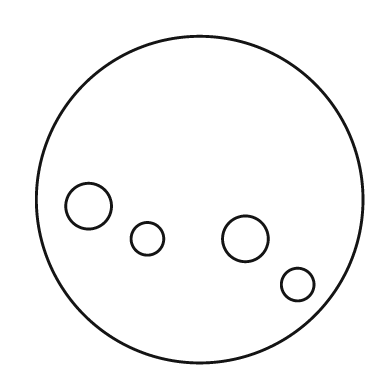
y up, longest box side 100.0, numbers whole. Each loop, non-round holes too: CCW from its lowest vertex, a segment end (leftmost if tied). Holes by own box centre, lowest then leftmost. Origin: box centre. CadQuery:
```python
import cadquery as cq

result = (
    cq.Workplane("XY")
    .moveTo(0.0, 0.0)
    .circle(50.0)
    .moveTo(30.0, -26.0)
    .circle(5.0)
    .moveTo(-16.0, -12.0)
    .circle(5.0)
    .moveTo(14.0, -12.0)
    .circle(7.0)
    .moveTo(-34.0, -2.0)
    .circle(7.0)
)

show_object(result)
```